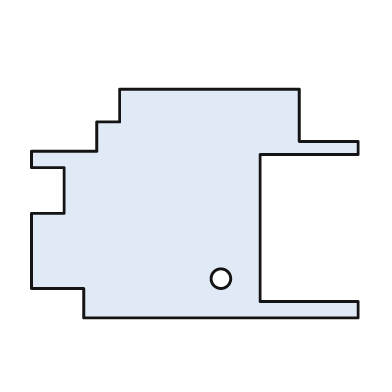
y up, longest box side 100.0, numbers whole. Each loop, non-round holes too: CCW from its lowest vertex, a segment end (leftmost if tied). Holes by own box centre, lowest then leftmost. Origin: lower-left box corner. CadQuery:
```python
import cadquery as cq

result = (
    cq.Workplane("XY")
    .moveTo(16.0, 0.0)
    .lineTo(100.0, 0.0)
    .lineTo(100.0, 5.0)
    .lineTo(70.0, 5.0)
    .lineTo(70.0, 50.0)
    .lineTo(100.0, 50.0)
    .lineTo(100.0, 54.0)
    .lineTo(82.0, 54.0)
    .lineTo(82.0, 70.0)
    .lineTo(27.0, 70.0)
    .lineTo(27.0, 60.0)
    .lineTo(20.0, 60.0)
    .lineTo(20.0, 51.0)
    .lineTo(0.0, 51.0)
    .lineTo(0.0, 46.0)
    .lineTo(10.0, 46.0)
    .lineTo(10.0, 32.0)
    .lineTo(0.0, 32.0)
    .lineTo(0.0, 9.0)
    .lineTo(16.0, 9.0)
    .close()
    .moveTo(58.0, 12.0)
    .circle(3.0)
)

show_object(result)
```